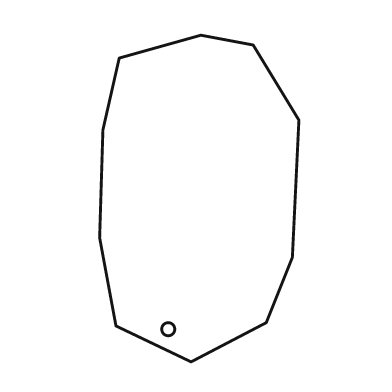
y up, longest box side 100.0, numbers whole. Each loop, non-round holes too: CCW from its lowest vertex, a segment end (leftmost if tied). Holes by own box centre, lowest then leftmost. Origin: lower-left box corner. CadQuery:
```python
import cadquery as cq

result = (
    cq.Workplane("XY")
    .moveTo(28.0, 0.0)
    .lineTo(51.0, 12.0)
    .lineTo(59.0, 32.0)
    .lineTo(61.0, 74.0)
    .lineTo(47.0, 97.0)
    .lineTo(31.0, 100.0)
    .lineTo(6.0, 93.0)
    .lineTo(1.0, 71.0)
    .lineTo(0.0, 38.0)
    .lineTo(5.0, 11.0)
    .close()
    .moveTo(21.0, 10.0)
    .circle(2.0)
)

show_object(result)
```